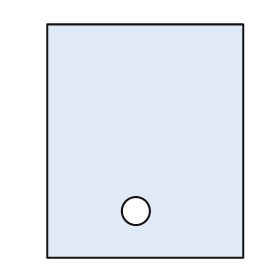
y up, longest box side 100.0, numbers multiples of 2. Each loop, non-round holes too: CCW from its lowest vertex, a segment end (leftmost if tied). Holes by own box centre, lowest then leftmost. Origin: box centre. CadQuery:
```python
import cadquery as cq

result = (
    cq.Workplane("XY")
    .moveTo(-42.0, -50.0)
    .lineTo(42.0, -50.0)
    .lineTo(42.0, 50.0)
    .lineTo(-42.0, 50.0)
    .close()
    .moveTo(-4.0, -30.0)
    .circle(6.0)
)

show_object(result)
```